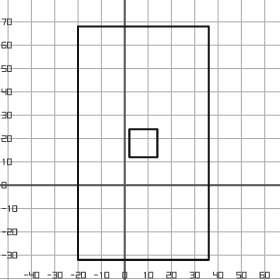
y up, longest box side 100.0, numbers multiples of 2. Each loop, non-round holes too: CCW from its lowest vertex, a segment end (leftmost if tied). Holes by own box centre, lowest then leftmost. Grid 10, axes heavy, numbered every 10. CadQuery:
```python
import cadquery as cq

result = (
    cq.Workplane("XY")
    .moveTo(-20.0, -32.0)
    .lineTo(36.0, -32.0)
    .lineTo(36.0, 68.0)
    .lineTo(-20.0, 68.0)
    .close()
    .moveTo(2.0, 12.0)
    .lineTo(14.0, 12.0)
    .lineTo(14.0, 24.0)
    .lineTo(2.0, 24.0)
    .close()
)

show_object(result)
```